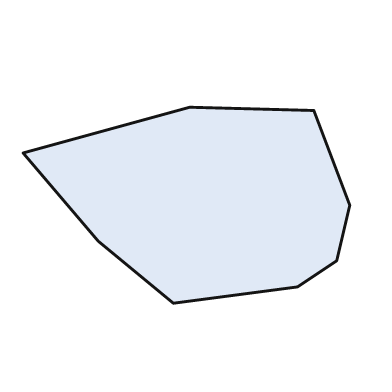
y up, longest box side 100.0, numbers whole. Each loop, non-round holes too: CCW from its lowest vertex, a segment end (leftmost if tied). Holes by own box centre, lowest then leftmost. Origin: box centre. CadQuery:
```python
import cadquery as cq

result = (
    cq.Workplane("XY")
    .moveTo(-4.0, -30.0)
    .lineTo(34.0, -25.0)
    .lineTo(46.0, -17.0)
    .lineTo(50.0, 0.0)
    .lineTo(39.0, 29.0)
    .lineTo(1.0, 30.0)
    .lineTo(-50.0, 16.0)
    .lineTo(-27.0, -11.0)
    .close()
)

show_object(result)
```